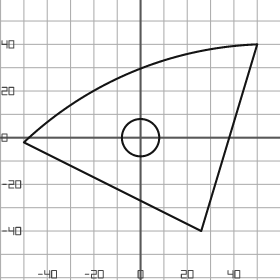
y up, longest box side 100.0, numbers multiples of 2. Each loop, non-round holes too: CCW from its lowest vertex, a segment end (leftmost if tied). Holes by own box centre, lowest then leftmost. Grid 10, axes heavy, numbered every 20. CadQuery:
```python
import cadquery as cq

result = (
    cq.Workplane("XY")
    .moveTo(26.0, -40.0)
    .lineTo(50.0, 40.0)
    .threePointArc((-4.0, 28.0), (-50.0, -2.0))
    .close()
    .moveTo(0.0, 0.0)
    .circle(8.0)
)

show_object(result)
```